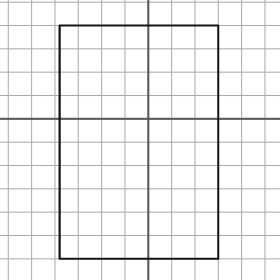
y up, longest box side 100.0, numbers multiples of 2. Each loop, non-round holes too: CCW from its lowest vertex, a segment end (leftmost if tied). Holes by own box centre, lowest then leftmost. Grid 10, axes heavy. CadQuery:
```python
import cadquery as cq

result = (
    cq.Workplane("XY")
    .moveTo(-38.0, -60.0)
    .lineTo(30.0, -60.0)
    .lineTo(30.0, 40.0)
    .lineTo(-38.0, 40.0)
    .close()
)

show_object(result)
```